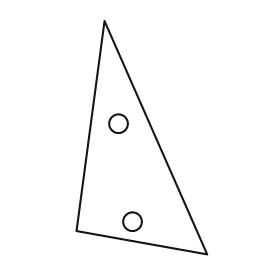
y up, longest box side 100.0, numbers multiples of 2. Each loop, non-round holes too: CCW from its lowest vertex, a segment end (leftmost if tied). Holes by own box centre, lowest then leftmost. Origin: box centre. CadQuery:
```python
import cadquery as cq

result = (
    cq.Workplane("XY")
    .moveTo(28.0, -50.0)
    .lineTo(-16.0, 50.0)
    .lineTo(-28.0, -40.0)
    .close()
    .moveTo(-4.0, -36.0)
    .circle(4.0)
    .moveTo(-10.0, 6.0)
    .circle(4.0)
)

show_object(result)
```